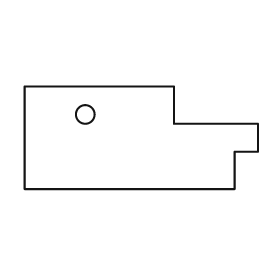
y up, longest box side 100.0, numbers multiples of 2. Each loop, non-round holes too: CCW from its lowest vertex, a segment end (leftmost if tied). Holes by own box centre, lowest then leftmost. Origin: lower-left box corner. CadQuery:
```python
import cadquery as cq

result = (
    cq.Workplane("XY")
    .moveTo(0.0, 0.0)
    .lineTo(90.0, 0.0)
    .lineTo(90.0, 16.0)
    .lineTo(100.0, 16.0)
    .lineTo(100.0, 28.0)
    .lineTo(64.0, 28.0)
    .lineTo(64.0, 44.0)
    .lineTo(0.0, 44.0)
    .close()
    .moveTo(26.0, 32.0)
    .circle(4.0)
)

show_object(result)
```